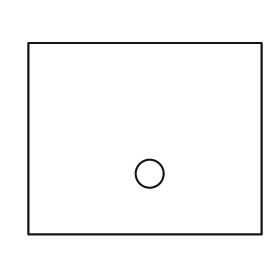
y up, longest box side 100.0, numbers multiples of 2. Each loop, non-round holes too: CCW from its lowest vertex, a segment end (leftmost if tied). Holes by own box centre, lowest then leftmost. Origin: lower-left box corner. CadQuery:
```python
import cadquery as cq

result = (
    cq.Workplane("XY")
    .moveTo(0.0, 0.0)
    .lineTo(100.0, 0.0)
    .lineTo(100.0, 82.0)
    .lineTo(0.0, 82.0)
    .close()
    .moveTo(52.0, 26.0)
    .circle(6.0)
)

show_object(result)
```